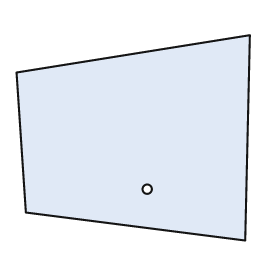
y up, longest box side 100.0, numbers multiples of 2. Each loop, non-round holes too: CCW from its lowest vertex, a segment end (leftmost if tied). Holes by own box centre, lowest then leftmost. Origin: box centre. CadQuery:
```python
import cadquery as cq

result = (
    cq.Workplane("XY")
    .moveTo(48.0, -44.0)
    .lineTo(50.0, 44.0)
    .lineTo(-50.0, 28.0)
    .lineTo(-46.0, -32.0)
    .close()
    .moveTo(6.0, -22.0)
    .circle(2.0)
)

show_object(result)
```